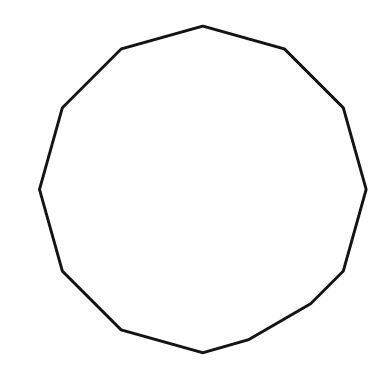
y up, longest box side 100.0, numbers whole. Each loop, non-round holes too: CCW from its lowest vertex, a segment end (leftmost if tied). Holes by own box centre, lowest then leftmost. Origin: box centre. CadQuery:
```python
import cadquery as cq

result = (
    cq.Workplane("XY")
    .moveTo(0.0, -50.0)
    .lineTo(14.0, -46.0)
    .lineTo(33.0, -35.0)
    .lineTo(43.0, -25.0)
    .lineTo(50.0, 0.0)
    .lineTo(43.0, 25.0)
    .lineTo(25.0, 43.0)
    .lineTo(0.0, 50.0)
    .lineTo(-25.0, 43.0)
    .lineTo(-43.0, 25.0)
    .lineTo(-50.0, 0.0)
    .lineTo(-43.0, -25.0)
    .lineTo(-25.0, -43.0)
    .close()
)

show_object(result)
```